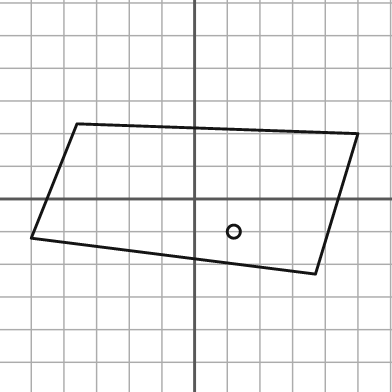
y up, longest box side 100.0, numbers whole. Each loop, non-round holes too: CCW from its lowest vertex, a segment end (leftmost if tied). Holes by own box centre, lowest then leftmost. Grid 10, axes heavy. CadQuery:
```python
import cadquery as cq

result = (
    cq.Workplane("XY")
    .moveTo(37.0, -23.0)
    .lineTo(50.0, 20.0)
    .lineTo(-36.0, 23.0)
    .lineTo(-50.0, -12.0)
    .close()
    .moveTo(12.0, -10.0)
    .circle(2.0)
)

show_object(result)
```